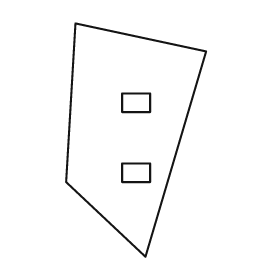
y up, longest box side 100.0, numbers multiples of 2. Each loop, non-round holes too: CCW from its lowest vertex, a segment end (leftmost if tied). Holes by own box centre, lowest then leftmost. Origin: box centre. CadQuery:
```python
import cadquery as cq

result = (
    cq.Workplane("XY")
    .moveTo(4.0, -50.0)
    .lineTo(30.0, 38.0)
    .lineTo(-26.0, 50.0)
    .lineTo(-30.0, -18.0)
    .close()
    .moveTo(-6.0, -18.0)
    .lineTo(6.0, -18.0)
    .lineTo(6.0, -10.0)
    .lineTo(-6.0, -10.0)
    .close()
    .moveTo(-6.0, 12.0)
    .lineTo(6.0, 12.0)
    .lineTo(6.0, 20.0)
    .lineTo(-6.0, 20.0)
    .close()
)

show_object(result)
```